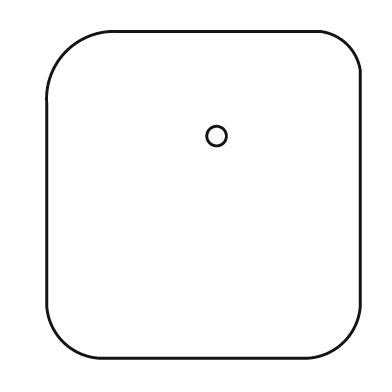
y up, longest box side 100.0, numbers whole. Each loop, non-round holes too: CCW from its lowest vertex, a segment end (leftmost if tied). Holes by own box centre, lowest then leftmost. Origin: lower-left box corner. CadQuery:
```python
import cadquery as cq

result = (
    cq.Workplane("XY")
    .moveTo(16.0, 0.0)
    .lineTo(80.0, 0.0)
    .threePointArc((91.0, 5.0), (96.0, 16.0))
    .lineTo(96.0, 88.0)
    .threePointArc((92.0, 96.0), (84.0, 100.0))
    .lineTo(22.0, 100.0)
    .threePointArc((6.0, 94.0), (0.0, 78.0))
    .lineTo(0.0, 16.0)
    .threePointArc((5.0, 5.0), (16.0, 0.0))
    .close()
    .moveTo(52.0, 68.0)
    .circle(3.0)
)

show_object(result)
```